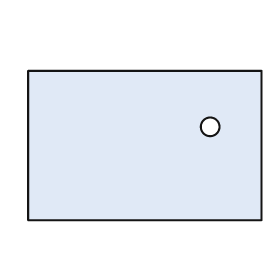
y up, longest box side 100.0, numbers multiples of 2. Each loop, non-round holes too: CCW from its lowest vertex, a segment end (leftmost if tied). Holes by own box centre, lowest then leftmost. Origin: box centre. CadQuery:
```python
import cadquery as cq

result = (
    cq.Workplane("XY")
    .moveTo(-50.0, -32.0)
    .lineTo(50.0, -32.0)
    .lineTo(50.0, 32.0)
    .lineTo(-50.0, 32.0)
    .close()
    .moveTo(28.0, 8.0)
    .circle(4.0)
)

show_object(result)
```